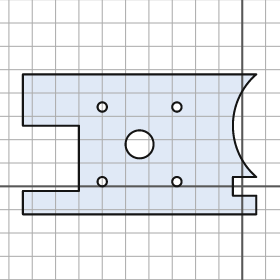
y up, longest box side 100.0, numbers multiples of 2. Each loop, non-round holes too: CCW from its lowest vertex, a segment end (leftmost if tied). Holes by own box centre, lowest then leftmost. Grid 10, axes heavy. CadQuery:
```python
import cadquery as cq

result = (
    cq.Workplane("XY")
    .moveTo(-94.0, -12.0)
    .lineTo(6.0, -12.0)
    .lineTo(6.0, -4.0)
    .lineTo(-4.0, -4.0)
    .lineTo(-4.0, 4.0)
    .lineTo(6.0, 4.0)
    .threePointArc((-4.0, 26.0), (6.0, 48.0))
    .lineTo(-94.0, 48.0)
    .lineTo(-94.0, 26.0)
    .lineTo(-70.0, 26.0)
    .lineTo(-70.0, -2.0)
    .lineTo(-94.0, -2.0)
    .close()
    .moveTo(-60.0, 2.0)
    .circle(2.0)
    .moveTo(-28.0, 2.0)
    .circle(2.0)
    .moveTo(-44.0, 18.0)
    .circle(6.0)
    .moveTo(-60.0, 34.0)
    .circle(2.0)
    .moveTo(-28.0, 34.0)
    .circle(2.0)
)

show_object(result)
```